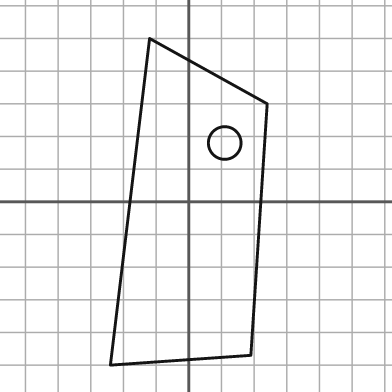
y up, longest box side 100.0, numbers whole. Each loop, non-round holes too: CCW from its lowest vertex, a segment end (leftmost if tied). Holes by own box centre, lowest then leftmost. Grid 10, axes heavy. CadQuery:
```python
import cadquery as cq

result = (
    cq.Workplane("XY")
    .moveTo(-24.0, -50.0)
    .lineTo(19.0, -47.0)
    .lineTo(24.0, 30.0)
    .lineTo(-12.0, 50.0)
    .close()
    .moveTo(11.0, 18.0)
    .circle(5.0)
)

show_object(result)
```